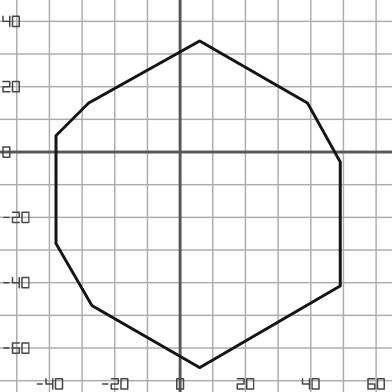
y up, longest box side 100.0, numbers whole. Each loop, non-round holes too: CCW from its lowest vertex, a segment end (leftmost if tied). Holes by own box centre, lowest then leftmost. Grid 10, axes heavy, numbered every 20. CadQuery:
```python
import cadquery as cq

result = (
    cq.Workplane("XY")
    .moveTo(6.0, -66.0)
    .lineTo(49.0, -41.0)
    .lineTo(49.0, -3.0)
    .lineTo(39.0, 15.0)
    .lineTo(6.0, 34.0)
    .lineTo(-28.0, 15.0)
    .lineTo(-38.0, 5.0)
    .lineTo(-38.0, -28.0)
    .lineTo(-27.0, -47.0)
    .close()
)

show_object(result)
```